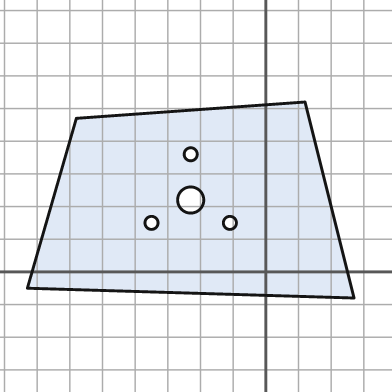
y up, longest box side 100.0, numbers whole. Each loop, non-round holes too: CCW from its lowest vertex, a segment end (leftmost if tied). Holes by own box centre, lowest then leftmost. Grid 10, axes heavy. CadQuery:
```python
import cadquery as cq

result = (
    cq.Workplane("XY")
    .moveTo(27.0, -8.0)
    .lineTo(12.0, 52.0)
    .lineTo(-58.0, 47.0)
    .lineTo(-73.0, -5.0)
    .close()
    .moveTo(-35.0, 15.0)
    .circle(2.0)
    .moveTo(-11.0, 15.0)
    .circle(2.0)
    .moveTo(-23.0, 22.0)
    .circle(4.0)
    .moveTo(-23.0, 36.0)
    .circle(2.0)
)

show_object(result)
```